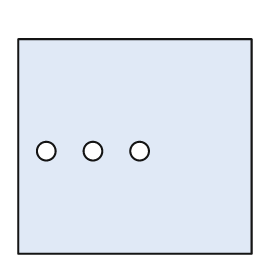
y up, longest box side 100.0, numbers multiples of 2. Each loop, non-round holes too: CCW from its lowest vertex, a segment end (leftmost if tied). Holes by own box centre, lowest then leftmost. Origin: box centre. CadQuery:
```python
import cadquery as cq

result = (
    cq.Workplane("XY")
    .moveTo(-50.0, -46.0)
    .lineTo(50.0, -46.0)
    .lineTo(50.0, 46.0)
    .lineTo(-50.0, 46.0)
    .close()
    .moveTo(-38.0, -2.0)
    .circle(4.0)
    .moveTo(-18.0, -2.0)
    .circle(4.0)
    .moveTo(2.0, -2.0)
    .circle(4.0)
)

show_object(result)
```